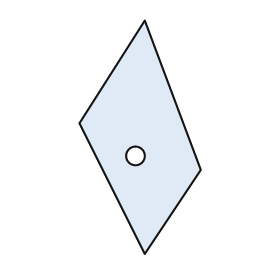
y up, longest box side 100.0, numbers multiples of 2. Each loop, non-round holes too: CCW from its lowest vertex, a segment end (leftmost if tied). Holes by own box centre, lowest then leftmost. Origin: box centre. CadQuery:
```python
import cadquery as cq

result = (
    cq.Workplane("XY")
    .moveTo(2.0, -50.0)
    .lineTo(26.0, -14.0)
    .lineTo(2.0, 50.0)
    .lineTo(-26.0, 6.0)
    .close()
    .moveTo(-2.0, -8.0)
    .circle(4.0)
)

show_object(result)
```